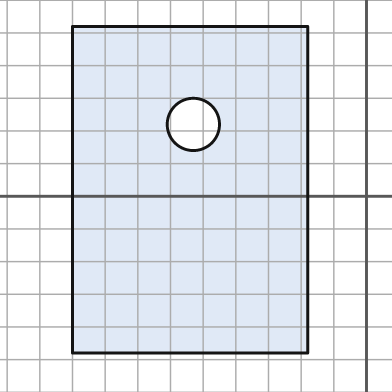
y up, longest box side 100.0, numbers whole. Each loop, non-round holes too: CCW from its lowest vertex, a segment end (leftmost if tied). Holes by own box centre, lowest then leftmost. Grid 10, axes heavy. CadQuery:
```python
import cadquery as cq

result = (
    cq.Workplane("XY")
    .moveTo(-90.0, -48.0)
    .lineTo(-18.0, -48.0)
    .lineTo(-18.0, 52.0)
    .lineTo(-90.0, 52.0)
    .close()
    .moveTo(-53.0, 22.0)
    .circle(8.0)
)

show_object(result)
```